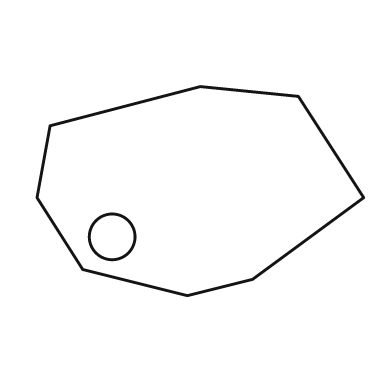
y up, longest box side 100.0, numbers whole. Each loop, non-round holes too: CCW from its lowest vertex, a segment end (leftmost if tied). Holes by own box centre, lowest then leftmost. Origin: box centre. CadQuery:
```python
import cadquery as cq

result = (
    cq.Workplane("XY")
    .moveTo(-4.0, -32.0)
    .lineTo(16.0, -27.0)
    .lineTo(50.0, -2.0)
    .lineTo(30.0, 29.0)
    .lineTo(0.0, 32.0)
    .lineTo(-46.0, 20.0)
    .lineTo(-50.0, -2.0)
    .lineTo(-36.0, -24.0)
    .close()
    .moveTo(-27.0, -14.0)
    .circle(7.0)
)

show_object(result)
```